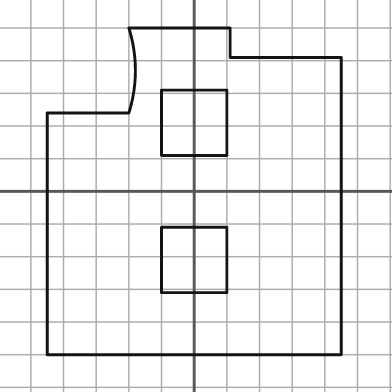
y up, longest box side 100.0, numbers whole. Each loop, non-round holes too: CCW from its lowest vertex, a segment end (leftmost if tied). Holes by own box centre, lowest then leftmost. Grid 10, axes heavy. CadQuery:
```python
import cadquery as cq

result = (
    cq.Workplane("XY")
    .moveTo(-45.0, -50.0)
    .lineTo(45.0, -50.0)
    .lineTo(45.0, 41.0)
    .lineTo(11.0, 41.0)
    .lineTo(11.0, 50.0)
    .lineTo(-20.0, 50.0)
    .threePointArc((-18.0, 37.0), (-20.0, 24.0))
    .lineTo(-45.0, 24.0)
    .close()
    .moveTo(-10.0, -31.0)
    .lineTo(10.0, -31.0)
    .lineTo(10.0, -11.0)
    .lineTo(-10.0, -11.0)
    .close()
    .moveTo(-10.0, 11.0)
    .lineTo(10.0, 11.0)
    .lineTo(10.0, 31.0)
    .lineTo(-10.0, 31.0)
    .close()
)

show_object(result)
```